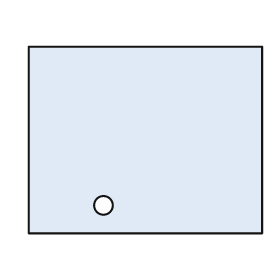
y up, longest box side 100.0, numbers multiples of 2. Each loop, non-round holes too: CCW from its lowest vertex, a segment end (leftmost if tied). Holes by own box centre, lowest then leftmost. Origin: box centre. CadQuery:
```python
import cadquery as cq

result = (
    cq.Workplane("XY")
    .moveTo(-50.0, -40.0)
    .lineTo(50.0, -40.0)
    .lineTo(50.0, 40.0)
    .lineTo(-50.0, 40.0)
    .close()
    .moveTo(-18.0, -28.0)
    .circle(4.0)
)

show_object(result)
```